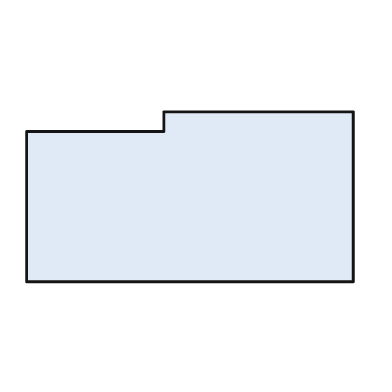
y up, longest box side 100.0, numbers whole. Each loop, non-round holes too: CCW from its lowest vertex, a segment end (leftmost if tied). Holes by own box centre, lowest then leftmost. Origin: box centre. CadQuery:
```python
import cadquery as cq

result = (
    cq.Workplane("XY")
    .moveTo(-50.0, -26.0)
    .lineTo(50.0, -26.0)
    .lineTo(50.0, 26.0)
    .lineTo(-8.0, 26.0)
    .lineTo(-8.0, 20.0)
    .lineTo(-50.0, 20.0)
    .close()
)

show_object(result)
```